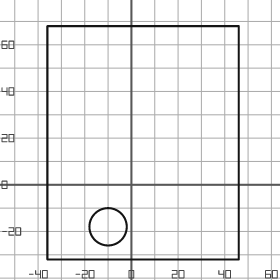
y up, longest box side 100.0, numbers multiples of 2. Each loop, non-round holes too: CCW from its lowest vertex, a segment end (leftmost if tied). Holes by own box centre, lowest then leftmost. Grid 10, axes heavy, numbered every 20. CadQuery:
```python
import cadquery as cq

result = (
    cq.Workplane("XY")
    .moveTo(-36.0, -32.0)
    .lineTo(46.0, -32.0)
    .lineTo(46.0, 68.0)
    .lineTo(-36.0, 68.0)
    .close()
    .moveTo(-10.0, -18.0)
    .circle(8.0)
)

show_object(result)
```